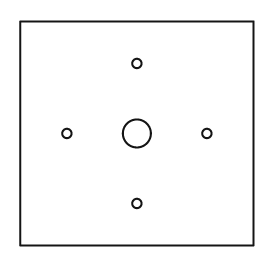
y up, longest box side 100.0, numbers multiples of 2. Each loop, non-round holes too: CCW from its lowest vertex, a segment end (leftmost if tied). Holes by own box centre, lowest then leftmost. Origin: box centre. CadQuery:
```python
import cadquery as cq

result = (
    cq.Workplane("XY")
    .moveTo(-50.0, -48.0)
    .lineTo(50.0, -48.0)
    .lineTo(50.0, 48.0)
    .lineTo(-50.0, 48.0)
    .close()
    .moveTo(0.0, -30.0)
    .circle(2.0)
    .moveTo(-30.0, 0.0)
    .circle(2.0)
    .moveTo(0.0, 0.0)
    .circle(6.0)
    .moveTo(30.0, 0.0)
    .circle(2.0)
    .moveTo(0.0, 30.0)
    .circle(2.0)
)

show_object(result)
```